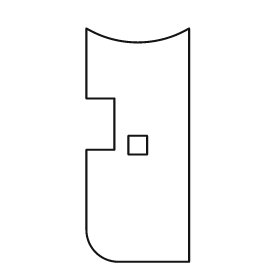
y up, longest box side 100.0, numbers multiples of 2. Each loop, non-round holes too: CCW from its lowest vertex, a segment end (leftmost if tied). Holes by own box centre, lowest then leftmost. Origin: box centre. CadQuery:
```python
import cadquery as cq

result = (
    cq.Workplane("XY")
    .moveTo(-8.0, -50.0)
    .lineTo(22.0, -50.0)
    .lineTo(22.0, 50.0)
    .threePointArc((0.0, 44.0), (-22.0, 50.0))
    .lineTo(-22.0, 20.0)
    .lineTo(-10.0, 20.0)
    .lineTo(-10.0, -2.0)
    .lineTo(-22.0, -2.0)
    .lineTo(-22.0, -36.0)
    .threePointArc((-18.0, -46.0), (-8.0, -50.0))
    .close()
    .moveTo(-4.0, -4.0)
    .lineTo(4.0, -4.0)
    .lineTo(4.0, 4.0)
    .lineTo(-4.0, 4.0)
    .close()
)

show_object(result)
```